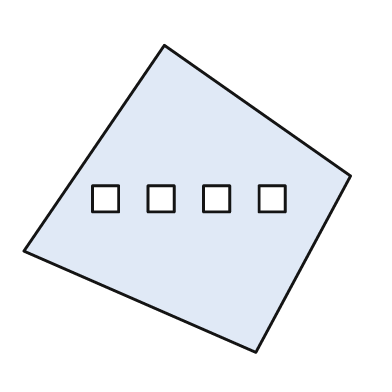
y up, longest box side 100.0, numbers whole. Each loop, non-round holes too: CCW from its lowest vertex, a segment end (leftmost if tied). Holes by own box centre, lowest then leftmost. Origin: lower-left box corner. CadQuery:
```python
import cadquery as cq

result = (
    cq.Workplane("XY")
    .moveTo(71.0, 0.0)
    .lineTo(100.0, 54.0)
    .lineTo(43.0, 94.0)
    .lineTo(0.0, 31.0)
    .close()
    .moveTo(21.0, 43.0)
    .lineTo(29.0, 43.0)
    .lineTo(29.0, 51.0)
    .lineTo(21.0, 51.0)
    .close()
    .moveTo(38.0, 43.0)
    .lineTo(46.0, 43.0)
    .lineTo(46.0, 51.0)
    .lineTo(38.0, 51.0)
    .close()
    .moveTo(55.0, 43.0)
    .lineTo(63.0, 43.0)
    .lineTo(63.0, 51.0)
    .lineTo(55.0, 51.0)
    .close()
    .moveTo(72.0, 43.0)
    .lineTo(80.0, 43.0)
    .lineTo(80.0, 51.0)
    .lineTo(72.0, 51.0)
    .close()
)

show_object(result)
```